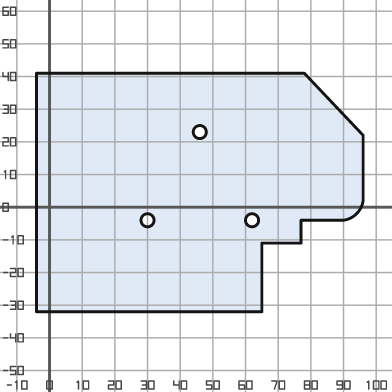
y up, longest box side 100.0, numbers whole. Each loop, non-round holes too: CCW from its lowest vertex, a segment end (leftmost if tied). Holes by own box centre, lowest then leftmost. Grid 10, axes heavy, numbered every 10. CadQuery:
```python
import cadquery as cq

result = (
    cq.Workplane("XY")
    .moveTo(-4.0, -32.0)
    .lineTo(65.0, -32.0)
    .lineTo(65.0, -11.0)
    .lineTo(77.0, -11.0)
    .lineTo(77.0, -4.0)
    .lineTo(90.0, -4.0)
    .threePointArc((94.0, -2.0), (96.0, 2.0))
    .lineTo(96.0, 22.0)
    .lineTo(78.0, 41.0)
    .lineTo(-4.0, 41.0)
    .close()
    .moveTo(30.0, -4.0)
    .circle(2.0)
    .moveTo(62.0, -4.0)
    .circle(2.0)
    .moveTo(46.0, 23.0)
    .circle(2.0)
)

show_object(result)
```